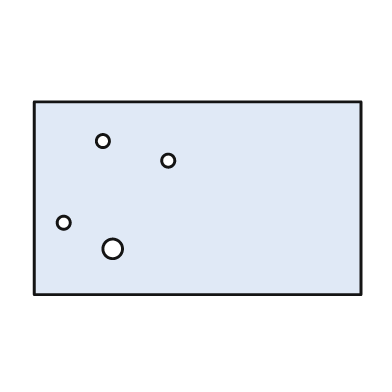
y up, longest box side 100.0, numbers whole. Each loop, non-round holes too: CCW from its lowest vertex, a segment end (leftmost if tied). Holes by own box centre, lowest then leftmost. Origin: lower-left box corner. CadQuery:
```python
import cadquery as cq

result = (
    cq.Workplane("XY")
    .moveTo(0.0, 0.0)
    .lineTo(100.0, 0.0)
    .lineTo(100.0, 59.0)
    .lineTo(0.0, 59.0)
    .close()
    .moveTo(24.0, 14.0)
    .circle(3.0)
    .moveTo(9.0, 22.0)
    .circle(2.0)
    .moveTo(41.0, 41.0)
    .circle(2.0)
    .moveTo(21.0, 47.0)
    .circle(2.0)
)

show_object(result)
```